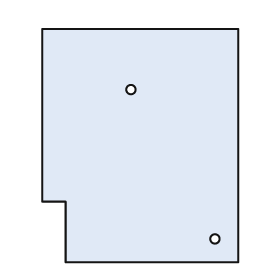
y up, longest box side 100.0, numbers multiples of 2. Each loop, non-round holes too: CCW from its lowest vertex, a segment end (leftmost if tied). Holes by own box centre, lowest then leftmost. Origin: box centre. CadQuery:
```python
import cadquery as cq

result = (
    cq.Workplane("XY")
    .moveTo(-32.0, -50.0)
    .lineTo(42.0, -50.0)
    .lineTo(42.0, 50.0)
    .lineTo(-42.0, 50.0)
    .lineTo(-42.0, -24.0)
    .lineTo(-32.0, -24.0)
    .close()
    .moveTo(32.0, -40.0)
    .circle(2.0)
    .moveTo(-4.0, 24.0)
    .circle(2.0)
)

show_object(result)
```